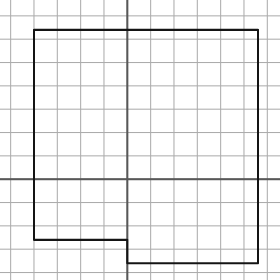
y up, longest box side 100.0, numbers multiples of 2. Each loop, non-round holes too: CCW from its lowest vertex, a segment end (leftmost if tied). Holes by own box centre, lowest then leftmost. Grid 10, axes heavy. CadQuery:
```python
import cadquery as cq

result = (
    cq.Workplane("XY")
    .moveTo(0.0, -36.0)
    .lineTo(56.0, -36.0)
    .lineTo(56.0, 64.0)
    .lineTo(-40.0, 64.0)
    .lineTo(-40.0, -26.0)
    .lineTo(0.0, -26.0)
    .close()
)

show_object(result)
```